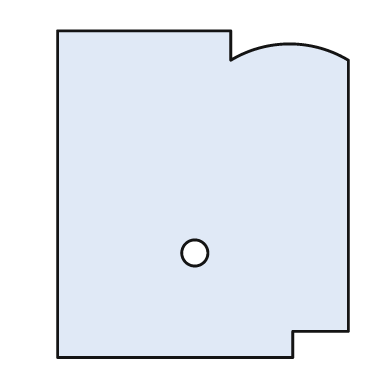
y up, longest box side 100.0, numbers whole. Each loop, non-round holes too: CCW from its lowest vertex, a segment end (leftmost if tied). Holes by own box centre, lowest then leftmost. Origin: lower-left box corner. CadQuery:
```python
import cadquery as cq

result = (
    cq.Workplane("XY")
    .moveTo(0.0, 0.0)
    .lineTo(72.0, 0.0)
    .lineTo(72.0, 8.0)
    .lineTo(89.0, 8.0)
    .lineTo(89.0, 91.0)
    .threePointArc((71.0, 96.0), (53.0, 91.0))
    .lineTo(53.0, 100.0)
    .lineTo(0.0, 100.0)
    .close()
    .moveTo(42.0, 32.0)
    .circle(4.0)
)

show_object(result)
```